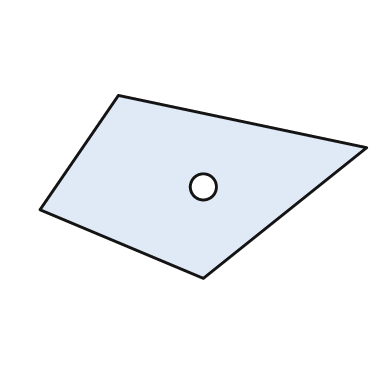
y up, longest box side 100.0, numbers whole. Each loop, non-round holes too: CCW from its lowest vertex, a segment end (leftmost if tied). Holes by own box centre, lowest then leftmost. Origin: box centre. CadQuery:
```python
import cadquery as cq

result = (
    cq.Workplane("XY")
    .moveTo(0.0, -28.0)
    .lineTo(50.0, 12.0)
    .lineTo(-26.0, 28.0)
    .lineTo(-50.0, -7.0)
    .close()
    .moveTo(0.0, 0.0)
    .circle(4.0)
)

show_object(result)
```